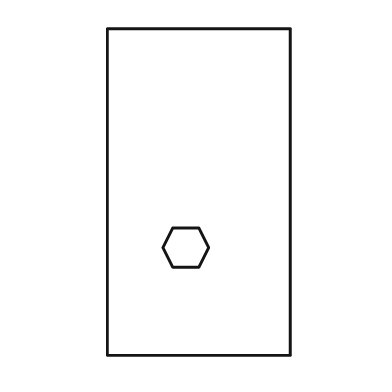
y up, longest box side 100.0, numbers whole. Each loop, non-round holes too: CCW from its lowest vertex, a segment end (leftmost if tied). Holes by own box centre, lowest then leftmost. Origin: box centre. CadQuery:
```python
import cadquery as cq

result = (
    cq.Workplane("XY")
    .moveTo(-28.0, -50.0)
    .lineTo(28.0, -50.0)
    .lineTo(28.0, 50.0)
    .lineTo(-28.0, 50.0)
    .close()
    .moveTo(-8.0, -23.0)
    .lineTo(0.0, -23.0)
    .lineTo(3.0, -17.0)
    .lineTo(0.0, -11.0)
    .lineTo(-8.0, -11.0)
    .lineTo(-11.0, -17.0)
    .close()
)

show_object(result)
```